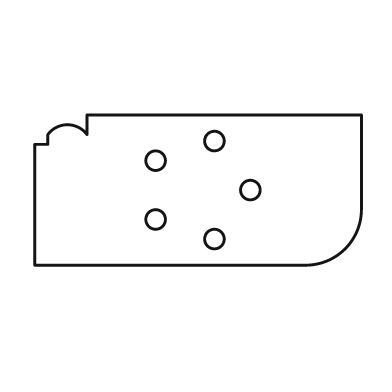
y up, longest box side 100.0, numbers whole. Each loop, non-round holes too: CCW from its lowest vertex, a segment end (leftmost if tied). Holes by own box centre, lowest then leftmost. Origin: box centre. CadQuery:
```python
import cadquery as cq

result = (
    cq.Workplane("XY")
    .moveTo(-50.0, -23.0)
    .lineTo(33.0, -23.0)
    .threePointArc((45.0, -18.0), (50.0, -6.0))
    .lineTo(50.0, 23.0)
    .lineTo(-34.0, 23.0)
    .lineTo(-34.0, 17.0)
    .threePointArc((-40.0, 20.0), (-46.0, 17.0))
    .lineTo(-46.0, 14.0)
    .lineTo(-50.0, 14.0)
    .close()
    .moveTo(5.0, -15.0)
    .circle(3.0)
    .moveTo(-13.0, -9.0)
    .circle(3.0)
    .moveTo(16.0, 0.0)
    .circle(3.0)
    .moveTo(-13.0, 9.0)
    .circle(3.0)
    .moveTo(5.0, 15.0)
    .circle(3.0)
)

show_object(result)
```